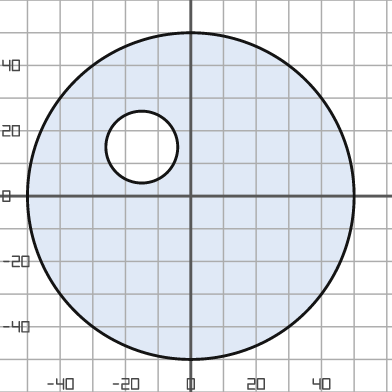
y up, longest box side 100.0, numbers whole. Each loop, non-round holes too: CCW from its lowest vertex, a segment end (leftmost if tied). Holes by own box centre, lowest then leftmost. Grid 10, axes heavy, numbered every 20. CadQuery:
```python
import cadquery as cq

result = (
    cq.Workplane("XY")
    .moveTo(0.0, 0.0)
    .circle(50.0)
    .moveTo(-15.0, 15.0)
    .circle(11.0)
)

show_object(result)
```